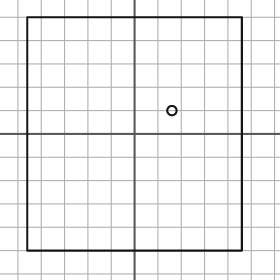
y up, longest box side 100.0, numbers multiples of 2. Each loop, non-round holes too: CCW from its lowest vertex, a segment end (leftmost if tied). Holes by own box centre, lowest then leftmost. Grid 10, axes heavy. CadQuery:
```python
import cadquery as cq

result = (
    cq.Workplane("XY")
    .moveTo(-46.0, -50.0)
    .lineTo(46.0, -50.0)
    .lineTo(46.0, 50.0)
    .lineTo(-46.0, 50.0)
    .close()
    .moveTo(16.0, 10.0)
    .circle(2.0)
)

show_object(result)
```